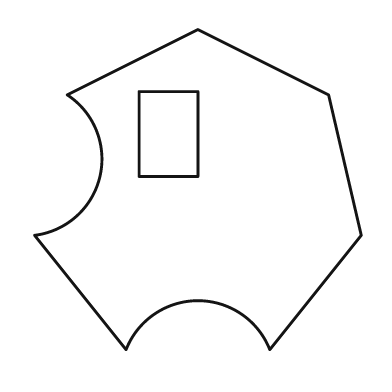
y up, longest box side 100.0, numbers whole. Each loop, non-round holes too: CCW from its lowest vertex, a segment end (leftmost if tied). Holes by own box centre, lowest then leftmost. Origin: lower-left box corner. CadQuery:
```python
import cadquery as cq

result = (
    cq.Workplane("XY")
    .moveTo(28.0, 0.0)
    .threePointArc((50.0, 15.0), (72.0, 0.0))
    .lineTo(100.0, 35.0)
    .lineTo(90.0, 78.0)
    .lineTo(50.0, 98.0)
    .lineTo(10.0, 78.0)
    .threePointArc((20.0, 53.0), (0.0, 35.0))
    .close()
    .moveTo(32.0, 53.0)
    .lineTo(50.0, 53.0)
    .lineTo(50.0, 79.0)
    .lineTo(32.0, 79.0)
    .close()
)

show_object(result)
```